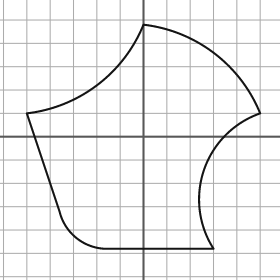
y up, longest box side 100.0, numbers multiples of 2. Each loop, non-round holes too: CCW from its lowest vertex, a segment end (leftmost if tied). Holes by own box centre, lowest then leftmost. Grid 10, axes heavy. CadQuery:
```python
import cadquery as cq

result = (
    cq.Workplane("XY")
    .moveTo(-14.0, -48.0)
    .lineTo(30.0, -48.0)
    .threePointArc((26.0, -14.0), (50.0, 10.0))
    .threePointArc((30.0, 36.0), (0.0, 48.0))
    .threePointArc((-20.0, 22.0), (-50.0, 10.0))
    .lineTo(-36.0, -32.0)
    .threePointArc((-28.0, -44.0), (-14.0, -48.0))
    .close()
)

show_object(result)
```